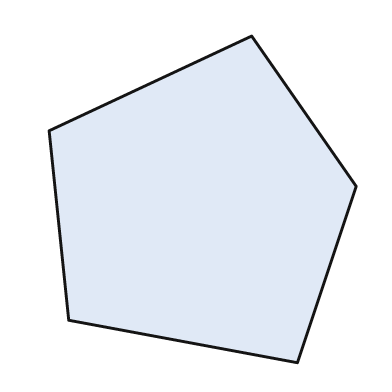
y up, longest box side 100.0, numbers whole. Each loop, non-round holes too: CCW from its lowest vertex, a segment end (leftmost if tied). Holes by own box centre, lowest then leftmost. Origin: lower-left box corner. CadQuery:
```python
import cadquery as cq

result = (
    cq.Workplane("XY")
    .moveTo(76.0, 0.0)
    .lineTo(94.0, 54.0)
    .lineTo(62.0, 100.0)
    .lineTo(0.0, 71.0)
    .lineTo(6.0, 13.0)
    .close()
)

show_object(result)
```